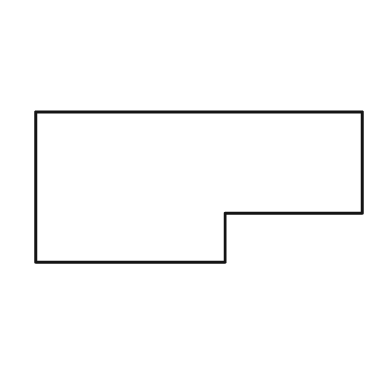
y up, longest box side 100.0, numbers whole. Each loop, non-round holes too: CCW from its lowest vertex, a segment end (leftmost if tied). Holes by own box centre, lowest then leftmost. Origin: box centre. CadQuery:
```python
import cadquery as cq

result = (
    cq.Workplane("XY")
    .moveTo(-50.0, -23.0)
    .lineTo(8.0, -23.0)
    .lineTo(8.0, -8.0)
    .lineTo(50.0, -8.0)
    .lineTo(50.0, 23.0)
    .lineTo(-50.0, 23.0)
    .close()
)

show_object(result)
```